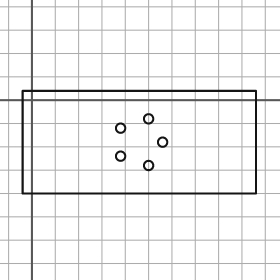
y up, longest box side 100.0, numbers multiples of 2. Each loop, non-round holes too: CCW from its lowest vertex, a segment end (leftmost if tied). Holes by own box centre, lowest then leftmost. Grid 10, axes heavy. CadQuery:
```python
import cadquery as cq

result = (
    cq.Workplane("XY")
    .moveTo(-4.0, -40.0)
    .lineTo(96.0, -40.0)
    .lineTo(96.0, 4.0)
    .lineTo(-4.0, 4.0)
    .close()
    .moveTo(50.0, -28.0)
    .circle(2.0)
    .moveTo(38.0, -24.0)
    .circle(2.0)
    .moveTo(56.0, -18.0)
    .circle(2.0)
    .moveTo(38.0, -12.0)
    .circle(2.0)
    .moveTo(50.0, -8.0)
    .circle(2.0)
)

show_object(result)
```